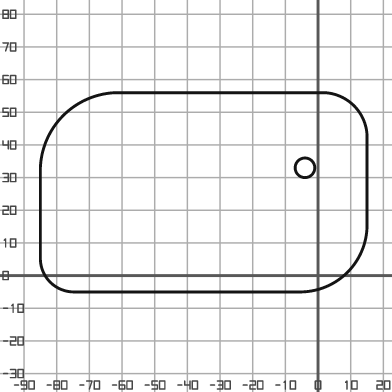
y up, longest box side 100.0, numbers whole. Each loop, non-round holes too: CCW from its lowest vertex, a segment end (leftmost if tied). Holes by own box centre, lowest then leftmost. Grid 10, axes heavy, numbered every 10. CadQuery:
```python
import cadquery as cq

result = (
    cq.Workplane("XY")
    .moveTo(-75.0, -5.0)
    .lineTo(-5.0, -5.0)
    .threePointArc((9.0, 1.0), (15.0, 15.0))
    .lineTo(15.0, 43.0)
    .threePointArc((11.0, 52.0), (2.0, 56.0))
    .lineTo(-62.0, 56.0)
    .threePointArc((-78.0, 49.0), (-85.0, 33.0))
    .lineTo(-85.0, 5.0)
    .threePointArc((-82.0, -2.0), (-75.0, -5.0))
    .close()
    .moveTo(-4.0, 33.0)
    .circle(3.0)
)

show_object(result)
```